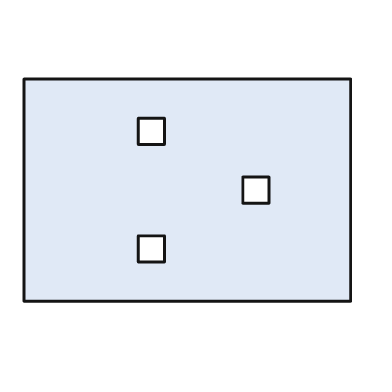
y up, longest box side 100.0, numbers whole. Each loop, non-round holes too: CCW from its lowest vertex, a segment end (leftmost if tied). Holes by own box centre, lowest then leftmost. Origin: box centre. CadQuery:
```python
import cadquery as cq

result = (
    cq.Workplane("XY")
    .moveTo(-50.0, -34.0)
    .lineTo(50.0, -34.0)
    .lineTo(50.0, 34.0)
    .lineTo(-50.0, 34.0)
    .close()
    .moveTo(-15.0, -22.0)
    .lineTo(-7.0, -22.0)
    .lineTo(-7.0, -14.0)
    .lineTo(-15.0, -14.0)
    .close()
    .moveTo(17.0, -4.0)
    .lineTo(25.0, -4.0)
    .lineTo(25.0, 4.0)
    .lineTo(17.0, 4.0)
    .close()
    .moveTo(-15.0, 14.0)
    .lineTo(-7.0, 14.0)
    .lineTo(-7.0, 22.0)
    .lineTo(-15.0, 22.0)
    .close()
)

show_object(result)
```